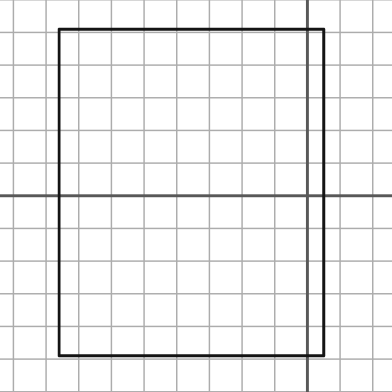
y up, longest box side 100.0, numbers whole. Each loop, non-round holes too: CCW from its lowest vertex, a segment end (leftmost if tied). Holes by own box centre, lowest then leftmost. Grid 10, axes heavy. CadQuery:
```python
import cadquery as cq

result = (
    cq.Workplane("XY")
    .moveTo(-76.0, -49.0)
    .lineTo(5.0, -49.0)
    .lineTo(5.0, 51.0)
    .lineTo(-76.0, 51.0)
    .close()
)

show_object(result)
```